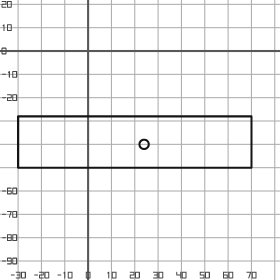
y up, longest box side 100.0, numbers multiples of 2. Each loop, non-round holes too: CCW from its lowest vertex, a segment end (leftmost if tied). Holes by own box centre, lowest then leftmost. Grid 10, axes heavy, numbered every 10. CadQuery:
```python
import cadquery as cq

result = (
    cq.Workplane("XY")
    .moveTo(-30.0, -50.0)
    .lineTo(70.0, -50.0)
    .lineTo(70.0, -28.0)
    .lineTo(-30.0, -28.0)
    .close()
    .moveTo(24.0, -40.0)
    .circle(2.0)
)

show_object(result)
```